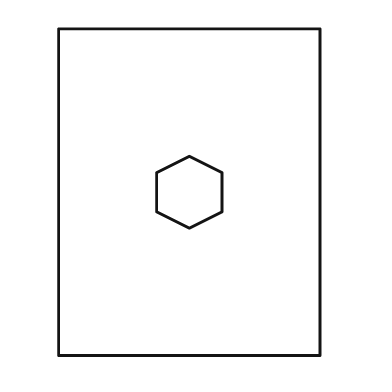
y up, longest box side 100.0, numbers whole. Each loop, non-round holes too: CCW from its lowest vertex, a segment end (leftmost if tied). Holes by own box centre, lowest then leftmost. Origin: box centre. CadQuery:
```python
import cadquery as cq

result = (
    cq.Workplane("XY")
    .moveTo(-40.0, -50.0)
    .lineTo(40.0, -50.0)
    .lineTo(40.0, 50.0)
    .lineTo(-40.0, 50.0)
    .close()
    .moveTo(0.0, -11.0)
    .lineTo(10.0, -6.0)
    .lineTo(10.0, 6.0)
    .lineTo(0.0, 11.0)
    .lineTo(-10.0, 6.0)
    .lineTo(-10.0, -6.0)
    .close()
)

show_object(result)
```